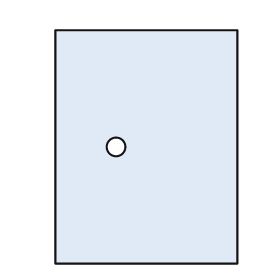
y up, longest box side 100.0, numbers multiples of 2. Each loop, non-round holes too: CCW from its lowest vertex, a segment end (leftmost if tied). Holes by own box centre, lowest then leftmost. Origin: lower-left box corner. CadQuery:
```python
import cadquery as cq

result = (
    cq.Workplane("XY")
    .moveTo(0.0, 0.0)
    .lineTo(78.0, 0.0)
    .lineTo(78.0, 100.0)
    .lineTo(0.0, 100.0)
    .close()
    .moveTo(26.0, 50.0)
    .circle(4.0)
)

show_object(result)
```